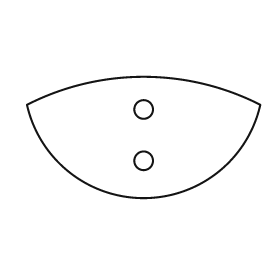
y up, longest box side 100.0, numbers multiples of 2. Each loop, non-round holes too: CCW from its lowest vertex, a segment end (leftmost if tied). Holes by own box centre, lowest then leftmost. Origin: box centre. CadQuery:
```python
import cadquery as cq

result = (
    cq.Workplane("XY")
    .moveTo(-50.0, 14.0)
    .threePointArc((0.0, -26.0), (50.0, 14.0))
    .threePointArc((0.0, 26.0), (-50.0, 14.0))
    .close()
    .moveTo(0.0, -10.0)
    .circle(4.0)
    .moveTo(0.0, 12.0)
    .circle(4.0)
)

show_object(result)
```